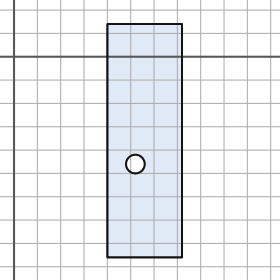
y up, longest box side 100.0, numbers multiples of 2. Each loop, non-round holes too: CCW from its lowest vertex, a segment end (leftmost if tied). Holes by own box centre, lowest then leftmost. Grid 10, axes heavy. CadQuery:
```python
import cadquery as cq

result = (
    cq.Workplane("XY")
    .moveTo(40.0, -86.0)
    .lineTo(72.0, -86.0)
    .lineTo(72.0, 14.0)
    .lineTo(40.0, 14.0)
    .close()
    .moveTo(52.0, -46.0)
    .circle(4.0)
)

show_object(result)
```